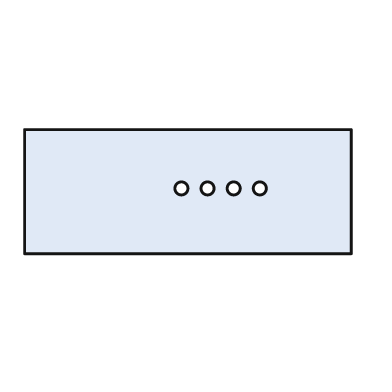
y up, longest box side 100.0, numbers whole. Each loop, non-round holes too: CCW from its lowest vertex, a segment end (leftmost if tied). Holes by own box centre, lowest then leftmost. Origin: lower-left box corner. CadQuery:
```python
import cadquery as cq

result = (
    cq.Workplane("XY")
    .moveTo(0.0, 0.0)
    .lineTo(100.0, 0.0)
    .lineTo(100.0, 38.0)
    .lineTo(0.0, 38.0)
    .close()
    .moveTo(48.0, 20.0)
    .circle(2.0)
    .moveTo(56.0, 20.0)
    .circle(2.0)
    .moveTo(64.0, 20.0)
    .circle(2.0)
    .moveTo(72.0, 20.0)
    .circle(2.0)
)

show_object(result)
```